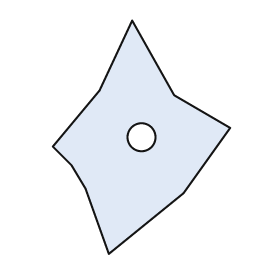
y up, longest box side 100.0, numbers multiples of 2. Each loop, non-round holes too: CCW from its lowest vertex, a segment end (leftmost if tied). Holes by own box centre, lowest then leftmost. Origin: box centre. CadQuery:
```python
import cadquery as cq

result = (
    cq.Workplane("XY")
    .moveTo(-14.0, -50.0)
    .lineTo(18.0, -24.0)
    .lineTo(38.0, 4.0)
    .lineTo(14.0, 18.0)
    .lineTo(-4.0, 50.0)
    .lineTo(-18.0, 20.0)
    .lineTo(-38.0, -4.0)
    .lineTo(-30.0, -12.0)
    .lineTo(-24.0, -22.0)
    .close()
    .moveTo(0.0, 0.0)
    .circle(6.0)
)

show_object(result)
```